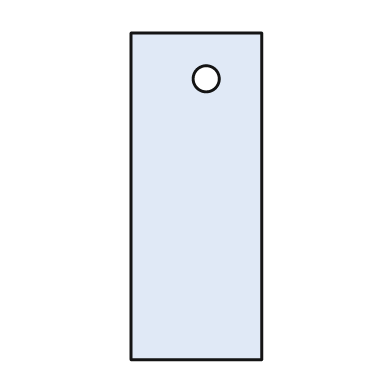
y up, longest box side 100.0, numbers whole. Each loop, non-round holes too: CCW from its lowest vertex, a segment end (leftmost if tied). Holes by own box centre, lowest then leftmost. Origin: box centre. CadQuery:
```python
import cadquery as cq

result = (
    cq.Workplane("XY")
    .moveTo(-20.0, -50.0)
    .lineTo(20.0, -50.0)
    .lineTo(20.0, 50.0)
    .lineTo(-20.0, 50.0)
    .close()
    .moveTo(3.0, 36.0)
    .circle(4.0)
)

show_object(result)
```